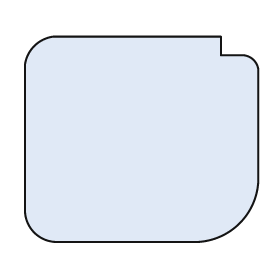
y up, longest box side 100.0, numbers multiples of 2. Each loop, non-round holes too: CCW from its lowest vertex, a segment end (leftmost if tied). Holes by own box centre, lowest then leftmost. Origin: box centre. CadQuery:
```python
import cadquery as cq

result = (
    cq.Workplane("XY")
    .moveTo(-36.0, -44.0)
    .lineTo(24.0, -44.0)
    .threePointArc((42.0, -36.0), (50.0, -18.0))
    .lineTo(50.0, 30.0)
    .threePointArc((48.0, 34.0), (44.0, 36.0))
    .lineTo(34.0, 36.0)
    .lineTo(34.0, 44.0)
    .lineTo(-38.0, 44.0)
    .threePointArc((-46.0, 40.0), (-50.0, 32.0))
    .lineTo(-50.0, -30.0)
    .threePointArc((-46.0, -40.0), (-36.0, -44.0))
    .close()
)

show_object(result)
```